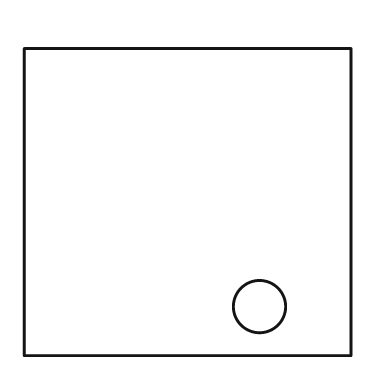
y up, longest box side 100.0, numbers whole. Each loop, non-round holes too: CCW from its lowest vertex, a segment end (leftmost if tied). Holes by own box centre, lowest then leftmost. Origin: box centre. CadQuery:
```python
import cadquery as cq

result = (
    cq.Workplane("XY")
    .moveTo(-50.0, -47.0)
    .lineTo(50.0, -47.0)
    .lineTo(50.0, 47.0)
    .lineTo(-50.0, 47.0)
    .close()
    .moveTo(22.0, -32.0)
    .circle(8.0)
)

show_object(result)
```